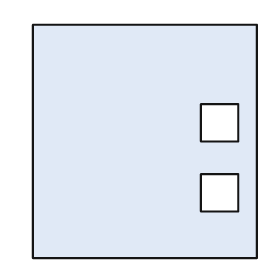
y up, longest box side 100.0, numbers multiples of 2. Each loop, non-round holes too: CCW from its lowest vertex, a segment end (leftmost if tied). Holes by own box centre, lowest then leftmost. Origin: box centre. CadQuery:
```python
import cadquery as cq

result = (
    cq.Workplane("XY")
    .moveTo(-48.0, -50.0)
    .lineTo(48.0, -50.0)
    .lineTo(48.0, 50.0)
    .lineTo(-48.0, 50.0)
    .close()
    .moveTo(24.0, -30.0)
    .lineTo(40.0, -30.0)
    .lineTo(40.0, -14.0)
    .lineTo(24.0, -14.0)
    .close()
    .moveTo(24.0, 0.0)
    .lineTo(40.0, 0.0)
    .lineTo(40.0, 16.0)
    .lineTo(24.0, 16.0)
    .close()
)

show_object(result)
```